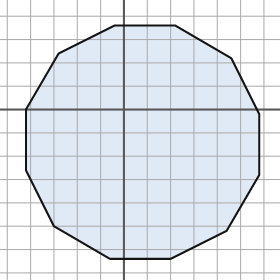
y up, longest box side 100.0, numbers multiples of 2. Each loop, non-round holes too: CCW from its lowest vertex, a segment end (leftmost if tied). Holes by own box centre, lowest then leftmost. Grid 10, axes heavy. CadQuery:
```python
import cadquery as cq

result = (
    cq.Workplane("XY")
    .moveTo(-6.0, -64.0)
    .lineTo(20.0, -64.0)
    .lineTo(44.0, -52.0)
    .lineTo(58.0, -28.0)
    .lineTo(58.0, -2.0)
    .lineTo(46.0, 22.0)
    .lineTo(22.0, 36.0)
    .lineTo(-4.0, 36.0)
    .lineTo(-28.0, 24.0)
    .lineTo(-42.0, 0.0)
    .lineTo(-42.0, -26.0)
    .lineTo(-30.0, -50.0)
    .close()
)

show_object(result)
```